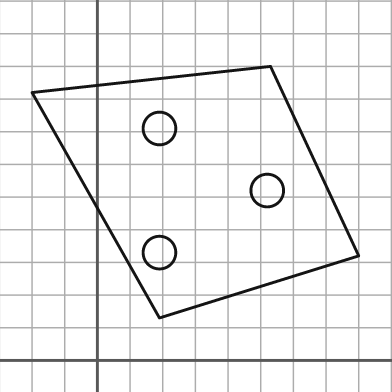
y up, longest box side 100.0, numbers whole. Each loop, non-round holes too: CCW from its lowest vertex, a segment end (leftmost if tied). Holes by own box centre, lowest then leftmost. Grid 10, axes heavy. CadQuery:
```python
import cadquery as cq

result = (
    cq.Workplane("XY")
    .moveTo(19.0, 13.0)
    .lineTo(80.0, 32.0)
    .lineTo(53.0, 90.0)
    .lineTo(-20.0, 82.0)
    .close()
    .moveTo(19.0, 33.0)
    .circle(5.0)
    .moveTo(52.0, 52.0)
    .circle(5.0)
    .moveTo(19.0, 71.0)
    .circle(5.0)
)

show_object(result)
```